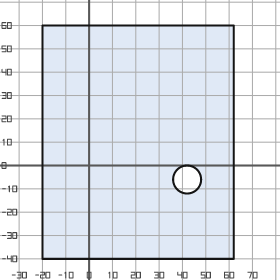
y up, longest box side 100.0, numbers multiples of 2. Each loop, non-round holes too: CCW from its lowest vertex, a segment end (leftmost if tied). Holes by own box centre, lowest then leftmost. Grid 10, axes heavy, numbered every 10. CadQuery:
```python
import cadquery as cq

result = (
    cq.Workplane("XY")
    .moveTo(-20.0, -40.0)
    .lineTo(62.0, -40.0)
    .lineTo(62.0, 60.0)
    .lineTo(-20.0, 60.0)
    .close()
    .moveTo(42.0, -6.0)
    .circle(6.0)
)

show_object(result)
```